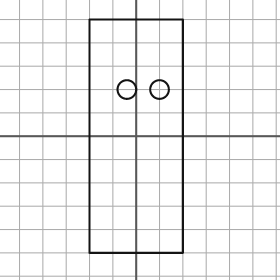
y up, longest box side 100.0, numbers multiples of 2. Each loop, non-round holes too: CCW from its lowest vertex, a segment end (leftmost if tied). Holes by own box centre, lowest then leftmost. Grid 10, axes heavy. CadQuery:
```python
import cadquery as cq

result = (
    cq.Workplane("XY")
    .moveTo(-20.0, -50.0)
    .lineTo(20.0, -50.0)
    .lineTo(20.0, 50.0)
    .lineTo(-20.0, 50.0)
    .close()
    .moveTo(-4.0, 20.0)
    .circle(4.0)
    .moveTo(10.0, 20.0)
    .circle(4.0)
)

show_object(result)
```